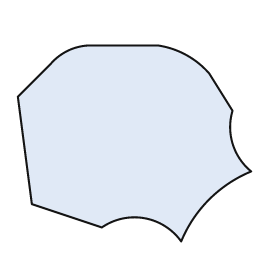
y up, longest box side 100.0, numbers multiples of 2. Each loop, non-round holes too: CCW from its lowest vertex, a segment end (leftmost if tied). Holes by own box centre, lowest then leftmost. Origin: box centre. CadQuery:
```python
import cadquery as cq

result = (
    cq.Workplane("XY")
    .moveTo(20.0, -42.0)
    .threePointArc((32.0, -24.0), (50.0, -12.0))
    .threePointArc((42.0, 0.0), (42.0, 14.0))
    .lineTo(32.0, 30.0)
    .threePointArc((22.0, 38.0), (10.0, 42.0))
    .lineTo(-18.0, 42.0)
    .threePointArc((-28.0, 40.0), (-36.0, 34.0))
    .lineTo(-50.0, 20.0)
    .lineTo(-44.0, -26.0)
    .lineTo(-14.0, -36.0)
    .threePointArc((4.0, -32.0), (20.0, -42.0))
    .close()
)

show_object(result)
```